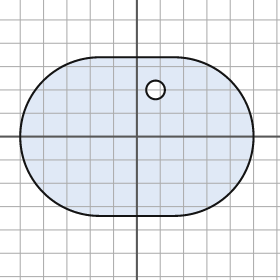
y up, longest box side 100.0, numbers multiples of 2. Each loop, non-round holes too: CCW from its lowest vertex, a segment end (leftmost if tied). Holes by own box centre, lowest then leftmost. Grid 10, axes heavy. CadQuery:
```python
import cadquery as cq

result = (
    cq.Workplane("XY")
    .moveTo(-16.0, -34.0)
    .lineTo(16.0, -34.0)
    .threePointArc((50.0, 0.0), (16.0, 34.0))
    .lineTo(-16.0, 34.0)
    .threePointArc((-50.0, 0.0), (-16.0, -34.0))
    .close()
    .moveTo(8.0, 20.0)
    .circle(4.0)
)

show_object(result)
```